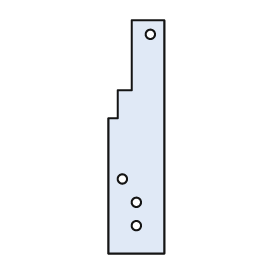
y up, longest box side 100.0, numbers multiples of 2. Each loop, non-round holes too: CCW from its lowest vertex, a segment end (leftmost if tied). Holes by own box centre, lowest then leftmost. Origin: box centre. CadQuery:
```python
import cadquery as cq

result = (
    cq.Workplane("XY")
    .moveTo(-12.0, -50.0)
    .lineTo(12.0, -50.0)
    .lineTo(12.0, 50.0)
    .lineTo(-2.0, 50.0)
    .lineTo(-2.0, 20.0)
    .lineTo(-8.0, 20.0)
    .lineTo(-8.0, 8.0)
    .lineTo(-12.0, 8.0)
    .close()
    .moveTo(0.0, -38.0)
    .circle(2.0)
    .moveTo(0.0, -28.0)
    .circle(2.0)
    .moveTo(-6.0, -18.0)
    .circle(2.0)
    .moveTo(6.0, 44.0)
    .circle(2.0)
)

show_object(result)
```